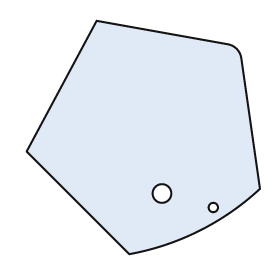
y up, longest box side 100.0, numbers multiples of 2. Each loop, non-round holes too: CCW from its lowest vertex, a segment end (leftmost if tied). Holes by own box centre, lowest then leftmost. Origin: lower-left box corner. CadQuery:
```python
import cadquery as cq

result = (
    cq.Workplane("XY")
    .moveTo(44.0, 0.0)
    .threePointArc((74.0, 10.0), (100.0, 28.0))
    .lineTo(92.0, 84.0)
    .threePointArc((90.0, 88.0), (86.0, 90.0))
    .lineTo(30.0, 100.0)
    .lineTo(0.0, 44.0)
    .close()
    .moveTo(80.0, 20.0)
    .circle(2.0)
    .moveTo(58.0, 26.0)
    .circle(4.0)
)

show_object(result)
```